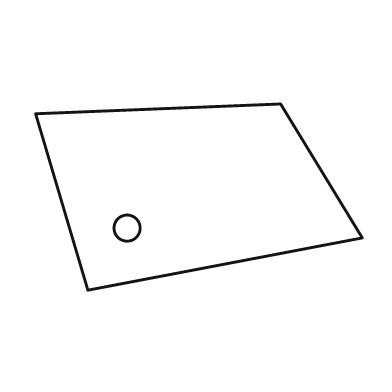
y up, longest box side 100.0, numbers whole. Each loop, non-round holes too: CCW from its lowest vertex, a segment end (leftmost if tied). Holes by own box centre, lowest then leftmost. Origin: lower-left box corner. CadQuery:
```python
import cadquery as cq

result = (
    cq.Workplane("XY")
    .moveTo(16.0, 0.0)
    .lineTo(100.0, 16.0)
    .lineTo(75.0, 57.0)
    .lineTo(0.0, 54.0)
    .close()
    .moveTo(28.0, 19.0)
    .circle(4.0)
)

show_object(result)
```